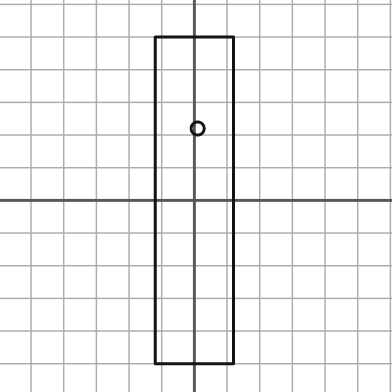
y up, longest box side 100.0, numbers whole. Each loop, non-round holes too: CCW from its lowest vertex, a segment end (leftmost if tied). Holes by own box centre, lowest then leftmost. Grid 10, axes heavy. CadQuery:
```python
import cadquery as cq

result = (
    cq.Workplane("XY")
    .moveTo(-12.0, -50.0)
    .lineTo(12.0, -50.0)
    .lineTo(12.0, 50.0)
    .lineTo(-12.0, 50.0)
    .close()
    .moveTo(1.0, 22.0)
    .circle(2.0)
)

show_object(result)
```